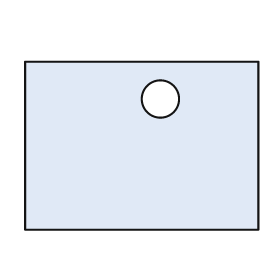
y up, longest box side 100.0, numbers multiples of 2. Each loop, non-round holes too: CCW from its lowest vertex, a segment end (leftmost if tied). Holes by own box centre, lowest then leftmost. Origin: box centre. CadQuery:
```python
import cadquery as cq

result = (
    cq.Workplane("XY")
    .moveTo(-50.0, -36.0)
    .lineTo(50.0, -36.0)
    .lineTo(50.0, 36.0)
    .lineTo(-50.0, 36.0)
    .close()
    .moveTo(8.0, 20.0)
    .circle(8.0)
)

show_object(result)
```